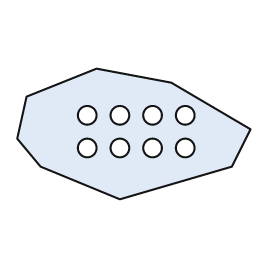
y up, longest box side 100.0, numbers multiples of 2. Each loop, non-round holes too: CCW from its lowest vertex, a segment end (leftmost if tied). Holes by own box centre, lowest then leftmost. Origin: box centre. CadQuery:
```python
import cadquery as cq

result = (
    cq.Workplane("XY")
    .moveTo(-6.0, -28.0)
    .lineTo(42.0, -14.0)
    .lineTo(50.0, 2.0)
    .lineTo(16.0, 22.0)
    .lineTo(-16.0, 28.0)
    .lineTo(-46.0, 16.0)
    .lineTo(-50.0, -2.0)
    .lineTo(-40.0, -14.0)
    .close()
    .moveTo(-20.0, -6.0)
    .circle(4.0)
    .moveTo(-6.0, -6.0)
    .circle(4.0)
    .moveTo(8.0, -6.0)
    .circle(4.0)
    .moveTo(22.0, -6.0)
    .circle(4.0)
    .moveTo(-20.0, 8.0)
    .circle(4.0)
    .moveTo(-6.0, 8.0)
    .circle(4.0)
    .moveTo(8.0, 8.0)
    .circle(4.0)
    .moveTo(22.0, 8.0)
    .circle(4.0)
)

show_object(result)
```